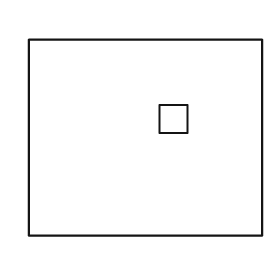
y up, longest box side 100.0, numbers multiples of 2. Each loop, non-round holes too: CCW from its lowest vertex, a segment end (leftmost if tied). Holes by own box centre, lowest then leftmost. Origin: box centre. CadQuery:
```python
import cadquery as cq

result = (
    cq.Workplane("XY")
    .moveTo(-50.0, -42.0)
    .lineTo(50.0, -42.0)
    .lineTo(50.0, 42.0)
    .lineTo(-50.0, 42.0)
    .close()
    .moveTo(6.0, 2.0)
    .lineTo(18.0, 2.0)
    .lineTo(18.0, 14.0)
    .lineTo(6.0, 14.0)
    .close()
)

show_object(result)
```